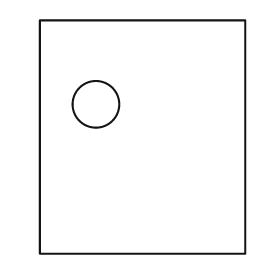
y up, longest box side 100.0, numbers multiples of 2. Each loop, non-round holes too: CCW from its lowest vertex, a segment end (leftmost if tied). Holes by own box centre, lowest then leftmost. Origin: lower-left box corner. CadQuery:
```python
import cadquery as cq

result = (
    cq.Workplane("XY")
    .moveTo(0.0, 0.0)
    .lineTo(88.0, 0.0)
    .lineTo(88.0, 100.0)
    .lineTo(0.0, 100.0)
    .close()
    .moveTo(24.0, 64.0)
    .circle(10.0)
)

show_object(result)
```